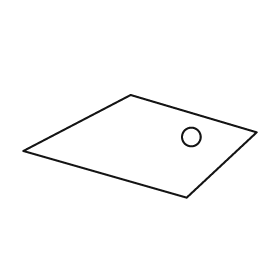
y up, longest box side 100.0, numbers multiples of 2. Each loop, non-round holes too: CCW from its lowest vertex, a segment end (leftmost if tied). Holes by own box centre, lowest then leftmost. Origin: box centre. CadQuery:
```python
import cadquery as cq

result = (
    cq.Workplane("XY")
    .moveTo(20.0, -22.0)
    .lineTo(50.0, 6.0)
    .lineTo(-4.0, 22.0)
    .lineTo(-50.0, -2.0)
    .close()
    .moveTo(22.0, 4.0)
    .circle(4.0)
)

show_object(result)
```